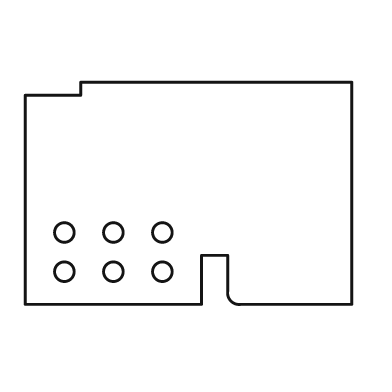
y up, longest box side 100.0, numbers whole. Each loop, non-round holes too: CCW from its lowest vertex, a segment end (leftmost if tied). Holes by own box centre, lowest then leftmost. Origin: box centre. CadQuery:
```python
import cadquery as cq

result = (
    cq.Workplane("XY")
    .moveTo(-50.0, -34.0)
    .lineTo(4.0, -34.0)
    .lineTo(4.0, -19.0)
    .lineTo(12.0, -19.0)
    .lineTo(12.0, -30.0)
    .threePointArc((13.0, -33.0), (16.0, -34.0))
    .lineTo(50.0, -34.0)
    .lineTo(50.0, 34.0)
    .lineTo(-33.0, 34.0)
    .lineTo(-33.0, 30.0)
    .lineTo(-50.0, 30.0)
    .close()
    .moveTo(-38.0, -24.0)
    .circle(3.0)
    .moveTo(-23.0, -24.0)
    .circle(3.0)
    .moveTo(-8.0, -24.0)
    .circle(3.0)
    .moveTo(-38.0, -12.0)
    .circle(3.0)
    .moveTo(-23.0, -12.0)
    .circle(3.0)
    .moveTo(-8.0, -12.0)
    .circle(3.0)
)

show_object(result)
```